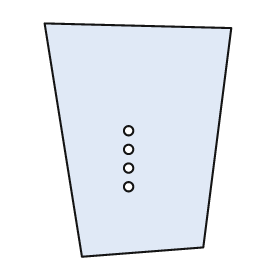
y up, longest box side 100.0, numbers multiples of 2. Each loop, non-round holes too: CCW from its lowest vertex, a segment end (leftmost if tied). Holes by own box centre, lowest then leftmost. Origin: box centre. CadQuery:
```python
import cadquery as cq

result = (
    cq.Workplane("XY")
    .moveTo(-24.0, -50.0)
    .lineTo(28.0, -46.0)
    .lineTo(40.0, 48.0)
    .lineTo(-40.0, 50.0)
    .close()
    .moveTo(-4.0, -20.0)
    .circle(2.0)
    .moveTo(-4.0, -12.0)
    .circle(2.0)
    .moveTo(-4.0, -4.0)
    .circle(2.0)
    .moveTo(-4.0, 4.0)
    .circle(2.0)
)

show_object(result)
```